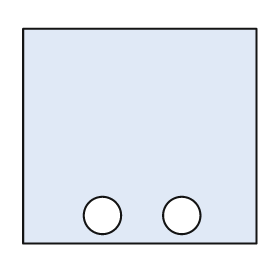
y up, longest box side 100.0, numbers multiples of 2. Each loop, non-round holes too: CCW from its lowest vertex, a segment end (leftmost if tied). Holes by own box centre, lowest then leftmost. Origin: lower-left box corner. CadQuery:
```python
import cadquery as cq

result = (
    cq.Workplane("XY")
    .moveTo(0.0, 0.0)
    .lineTo(100.0, 0.0)
    .lineTo(100.0, 92.0)
    .lineTo(0.0, 92.0)
    .close()
    .moveTo(34.0, 12.0)
    .circle(8.0)
    .moveTo(68.0, 12.0)
    .circle(8.0)
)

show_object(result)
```